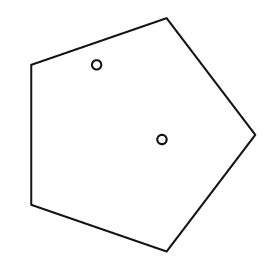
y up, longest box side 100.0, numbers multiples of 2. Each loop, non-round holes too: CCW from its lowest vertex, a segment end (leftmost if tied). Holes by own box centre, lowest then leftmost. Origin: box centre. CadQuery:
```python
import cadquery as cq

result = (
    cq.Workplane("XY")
    .moveTo(10.0, -50.0)
    .lineTo(48.0, 0.0)
    .lineTo(10.0, 50.0)
    .lineTo(-48.0, 30.0)
    .lineTo(-48.0, -30.0)
    .close()
    .moveTo(8.0, -2.0)
    .circle(2.0)
    .moveTo(-20.0, 30.0)
    .circle(2.0)
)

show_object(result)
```